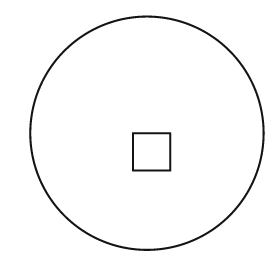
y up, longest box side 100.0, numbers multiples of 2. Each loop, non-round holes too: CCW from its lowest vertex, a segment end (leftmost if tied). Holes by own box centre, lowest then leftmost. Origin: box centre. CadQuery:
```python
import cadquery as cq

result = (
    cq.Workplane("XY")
    .moveTo(0.0, 0.0)
    .circle(50.0)
    .moveTo(-6.0, -16.0)
    .lineTo(10.0, -16.0)
    .lineTo(10.0, 0.0)
    .lineTo(-6.0, 0.0)
    .close()
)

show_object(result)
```